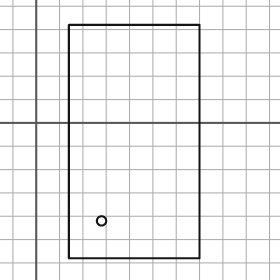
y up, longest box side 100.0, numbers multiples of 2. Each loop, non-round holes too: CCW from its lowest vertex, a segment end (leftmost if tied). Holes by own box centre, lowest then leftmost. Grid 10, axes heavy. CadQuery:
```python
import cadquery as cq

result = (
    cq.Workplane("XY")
    .moveTo(14.0, -58.0)
    .lineTo(70.0, -58.0)
    .lineTo(70.0, 42.0)
    .lineTo(14.0, 42.0)
    .close()
    .moveTo(28.0, -42.0)
    .circle(2.0)
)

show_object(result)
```